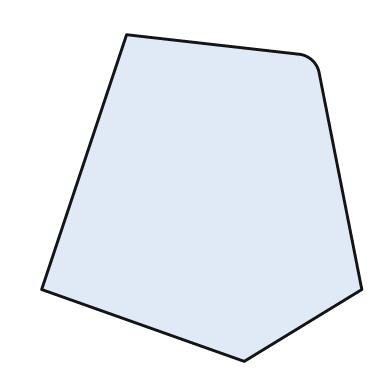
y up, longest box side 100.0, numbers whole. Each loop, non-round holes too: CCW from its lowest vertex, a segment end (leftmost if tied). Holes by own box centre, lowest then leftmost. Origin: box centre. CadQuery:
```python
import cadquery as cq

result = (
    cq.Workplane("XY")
    .moveTo(13.0, -50.0)
    .lineTo(49.0, -28.0)
    .lineTo(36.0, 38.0)
    .threePointArc((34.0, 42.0), (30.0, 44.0))
    .lineTo(-23.0, 50.0)
    .lineTo(-49.0, -28.0)
    .close()
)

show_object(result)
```